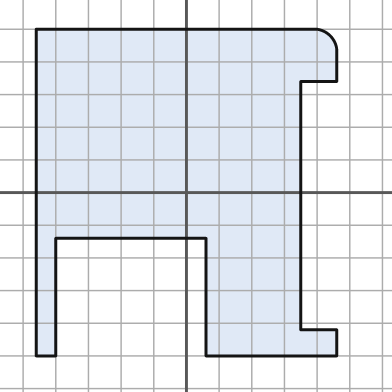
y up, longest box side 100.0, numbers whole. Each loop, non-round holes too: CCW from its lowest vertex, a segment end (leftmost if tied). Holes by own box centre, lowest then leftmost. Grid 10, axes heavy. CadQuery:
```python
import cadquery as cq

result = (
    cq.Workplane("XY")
    .moveTo(-46.0, -50.0)
    .lineTo(-40.0, -50.0)
    .lineTo(-40.0, -14.0)
    .lineTo(6.0, -14.0)
    .lineTo(6.0, -50.0)
    .lineTo(46.0, -50.0)
    .lineTo(46.0, -42.0)
    .lineTo(35.0, -42.0)
    .lineTo(35.0, 34.0)
    .lineTo(46.0, 34.0)
    .lineTo(46.0, 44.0)
    .threePointArc((44.0, 48.0), (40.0, 50.0))
    .lineTo(-46.0, 50.0)
    .close()
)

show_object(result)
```